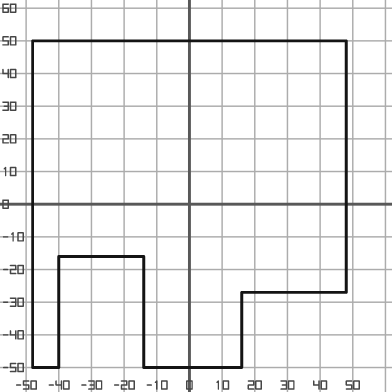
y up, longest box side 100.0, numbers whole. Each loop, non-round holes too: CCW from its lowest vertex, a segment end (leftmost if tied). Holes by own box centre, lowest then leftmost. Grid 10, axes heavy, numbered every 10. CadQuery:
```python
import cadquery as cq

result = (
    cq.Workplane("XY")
    .moveTo(-48.0, -50.0)
    .lineTo(-40.0, -50.0)
    .lineTo(-40.0, -16.0)
    .lineTo(-14.0, -16.0)
    .lineTo(-14.0, -50.0)
    .lineTo(16.0, -50.0)
    .lineTo(16.0, -27.0)
    .lineTo(48.0, -27.0)
    .lineTo(48.0, 50.0)
    .lineTo(-48.0, 50.0)
    .close()
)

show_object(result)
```